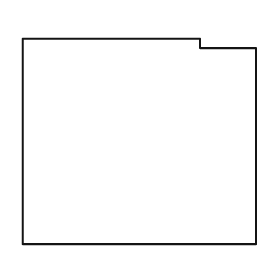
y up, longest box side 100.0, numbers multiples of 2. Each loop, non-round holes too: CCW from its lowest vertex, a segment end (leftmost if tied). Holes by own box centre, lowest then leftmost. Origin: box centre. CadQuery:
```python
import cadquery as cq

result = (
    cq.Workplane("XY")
    .moveTo(-50.0, -44.0)
    .lineTo(50.0, -44.0)
    .lineTo(50.0, 40.0)
    .lineTo(26.0, 40.0)
    .lineTo(26.0, 44.0)
    .lineTo(-50.0, 44.0)
    .close()
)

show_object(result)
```